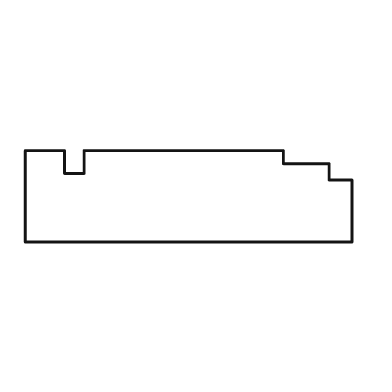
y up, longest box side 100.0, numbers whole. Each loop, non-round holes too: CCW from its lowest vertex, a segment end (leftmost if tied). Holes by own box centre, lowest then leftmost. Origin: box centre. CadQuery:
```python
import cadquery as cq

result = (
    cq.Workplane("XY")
    .moveTo(-50.0, -14.0)
    .lineTo(50.0, -14.0)
    .lineTo(50.0, 5.0)
    .lineTo(43.0, 5.0)
    .lineTo(43.0, 10.0)
    .lineTo(29.0, 10.0)
    .lineTo(29.0, 14.0)
    .lineTo(-32.0, 14.0)
    .lineTo(-32.0, 7.0)
    .lineTo(-38.0, 7.0)
    .lineTo(-38.0, 14.0)
    .lineTo(-50.0, 14.0)
    .close()
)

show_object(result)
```